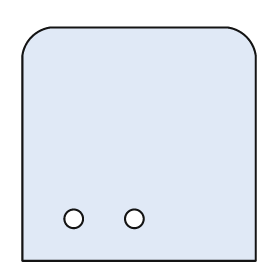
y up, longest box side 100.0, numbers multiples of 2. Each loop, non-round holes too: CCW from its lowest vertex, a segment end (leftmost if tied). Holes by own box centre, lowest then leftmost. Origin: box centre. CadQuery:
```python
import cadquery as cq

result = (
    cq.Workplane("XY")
    .moveTo(-50.0, -50.0)
    .lineTo(50.0, -50.0)
    .lineTo(50.0, 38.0)
    .threePointArc((46.0, 46.0), (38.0, 50.0))
    .lineTo(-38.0, 50.0)
    .threePointArc((-46.0, 46.0), (-50.0, 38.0))
    .close()
    .moveTo(-28.0, -32.0)
    .circle(4.0)
    .moveTo(-2.0, -32.0)
    .circle(4.0)
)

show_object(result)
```